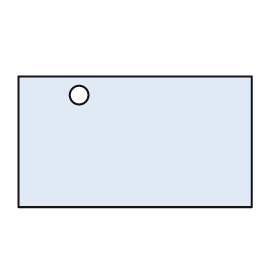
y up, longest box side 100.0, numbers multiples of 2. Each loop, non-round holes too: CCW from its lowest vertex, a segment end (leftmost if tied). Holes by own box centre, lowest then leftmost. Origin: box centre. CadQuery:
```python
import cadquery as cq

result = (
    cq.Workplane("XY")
    .moveTo(-50.0, -28.0)
    .lineTo(50.0, -28.0)
    .lineTo(50.0, 28.0)
    .lineTo(-50.0, 28.0)
    .close()
    .moveTo(-24.0, 20.0)
    .circle(4.0)
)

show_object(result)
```